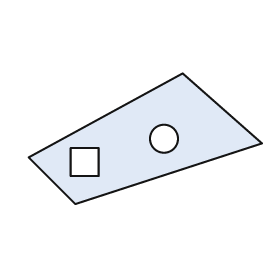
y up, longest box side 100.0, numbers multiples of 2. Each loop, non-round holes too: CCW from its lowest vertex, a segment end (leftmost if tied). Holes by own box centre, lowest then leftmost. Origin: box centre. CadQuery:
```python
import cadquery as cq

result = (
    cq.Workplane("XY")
    .moveTo(-30.0, -28.0)
    .lineTo(50.0, -2.0)
    .lineTo(16.0, 28.0)
    .lineTo(-50.0, -8.0)
    .close()
    .moveTo(-32.0, -16.0)
    .lineTo(-20.0, -16.0)
    .lineTo(-20.0, -4.0)
    .lineTo(-32.0, -4.0)
    .close()
    .moveTo(8.0, 0.0)
    .circle(6.0)
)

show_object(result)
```